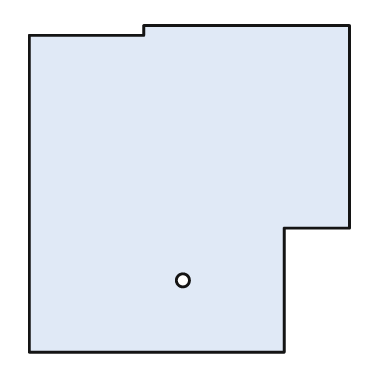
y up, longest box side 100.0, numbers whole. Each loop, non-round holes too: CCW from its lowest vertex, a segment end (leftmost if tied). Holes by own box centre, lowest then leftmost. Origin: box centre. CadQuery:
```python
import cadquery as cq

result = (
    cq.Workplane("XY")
    .moveTo(-49.0, -50.0)
    .lineTo(29.0, -50.0)
    .lineTo(29.0, -12.0)
    .lineTo(49.0, -12.0)
    .lineTo(49.0, 50.0)
    .lineTo(-14.0, 50.0)
    .lineTo(-14.0, 47.0)
    .lineTo(-49.0, 47.0)
    .close()
    .moveTo(-2.0, -28.0)
    .circle(2.0)
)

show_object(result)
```